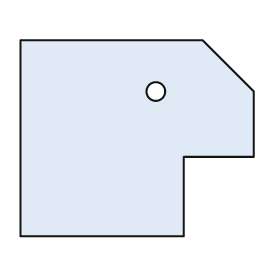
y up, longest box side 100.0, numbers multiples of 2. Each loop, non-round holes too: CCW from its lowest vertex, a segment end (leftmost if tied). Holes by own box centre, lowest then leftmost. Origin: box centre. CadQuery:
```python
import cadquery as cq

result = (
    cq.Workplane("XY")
    .moveTo(-50.0, -42.0)
    .lineTo(20.0, -42.0)
    .lineTo(20.0, -8.0)
    .lineTo(50.0, -8.0)
    .lineTo(50.0, 20.0)
    .lineTo(28.0, 42.0)
    .lineTo(-50.0, 42.0)
    .close()
    .moveTo(8.0, 20.0)
    .circle(4.0)
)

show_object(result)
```